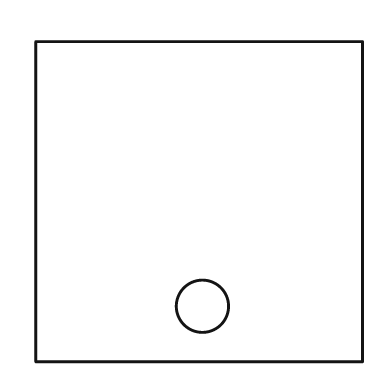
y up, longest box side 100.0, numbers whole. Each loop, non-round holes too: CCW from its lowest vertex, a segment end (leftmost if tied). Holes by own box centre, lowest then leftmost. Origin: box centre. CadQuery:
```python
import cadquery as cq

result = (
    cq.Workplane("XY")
    .moveTo(-50.0, -49.0)
    .lineTo(50.0, -49.0)
    .lineTo(50.0, 49.0)
    .lineTo(-50.0, 49.0)
    .close()
    .moveTo(1.0, -32.0)
    .circle(8.0)
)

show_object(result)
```